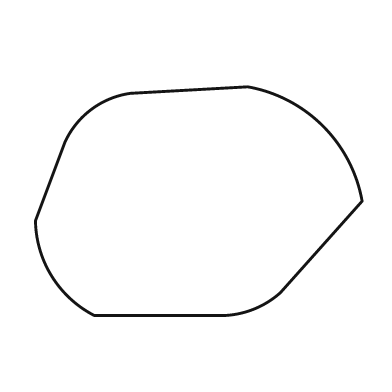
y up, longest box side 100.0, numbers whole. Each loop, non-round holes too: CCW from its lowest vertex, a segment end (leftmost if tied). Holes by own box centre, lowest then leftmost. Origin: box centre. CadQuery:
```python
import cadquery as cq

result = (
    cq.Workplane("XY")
    .moveTo(-32.0, -35.0)
    .lineTo(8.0, -35.0)
    .threePointArc((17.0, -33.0), (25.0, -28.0))
    .lineTo(50.0, 0.0)
    .threePointArc((38.0, 23.0), (15.0, 35.0))
    .lineTo(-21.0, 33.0)
    .threePointArc((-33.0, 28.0), (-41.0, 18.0))
    .lineTo(-50.0, -6.0)
    .threePointArc((-45.0, -23.0), (-32.0, -35.0))
    .close()
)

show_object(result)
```